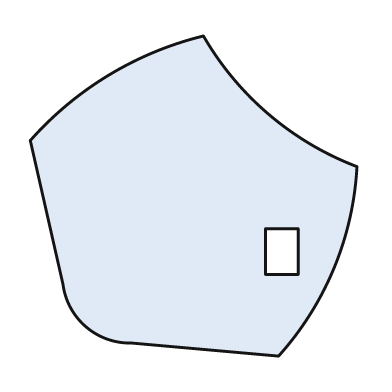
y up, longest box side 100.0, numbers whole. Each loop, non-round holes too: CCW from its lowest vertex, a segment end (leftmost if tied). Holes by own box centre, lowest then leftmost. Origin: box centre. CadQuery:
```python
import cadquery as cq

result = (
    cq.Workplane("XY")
    .moveTo(26.0, -49.0)
    .threePointArc((43.0, -22.0), (50.0, 9.0))
    .threePointArc((23.0, 25.0), (3.0, 49.0))
    .threePointArc((-26.0, 37.0), (-50.0, 17.0))
    .lineTo(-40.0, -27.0)
    .threePointArc((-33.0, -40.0), (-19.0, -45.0))
    .close()
    .moveTo(22.0, -24.0)
    .lineTo(32.0, -24.0)
    .lineTo(32.0, -10.0)
    .lineTo(22.0, -10.0)
    .close()
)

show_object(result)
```